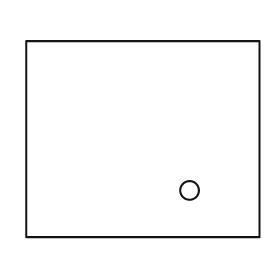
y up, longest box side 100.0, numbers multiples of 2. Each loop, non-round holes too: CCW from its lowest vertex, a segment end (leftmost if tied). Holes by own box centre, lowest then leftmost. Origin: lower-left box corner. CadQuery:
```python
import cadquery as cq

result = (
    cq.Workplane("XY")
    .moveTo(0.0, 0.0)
    .lineTo(100.0, 0.0)
    .lineTo(100.0, 84.0)
    .lineTo(0.0, 84.0)
    .close()
    .moveTo(70.0, 20.0)
    .circle(4.0)
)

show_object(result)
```